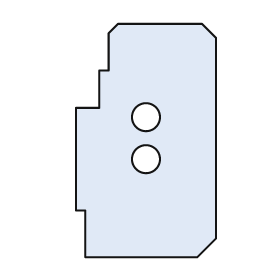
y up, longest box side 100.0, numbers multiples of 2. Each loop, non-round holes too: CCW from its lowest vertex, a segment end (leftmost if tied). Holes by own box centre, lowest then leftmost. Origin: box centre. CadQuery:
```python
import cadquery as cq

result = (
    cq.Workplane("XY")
    .moveTo(-26.0, -50.0)
    .lineTo(22.0, -50.0)
    .lineTo(30.0, -42.0)
    .lineTo(30.0, 44.0)
    .lineTo(24.0, 50.0)
    .lineTo(-12.0, 50.0)
    .lineTo(-16.0, 46.0)
    .lineTo(-16.0, 30.0)
    .lineTo(-20.0, 30.0)
    .lineTo(-20.0, 14.0)
    .lineTo(-30.0, 14.0)
    .lineTo(-30.0, -30.0)
    .lineTo(-26.0, -30.0)
    .close()
    .moveTo(0.0, -8.0)
    .circle(6.0)
    .moveTo(0.0, 10.0)
    .circle(6.0)
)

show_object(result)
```